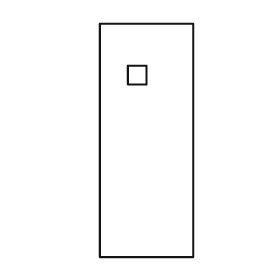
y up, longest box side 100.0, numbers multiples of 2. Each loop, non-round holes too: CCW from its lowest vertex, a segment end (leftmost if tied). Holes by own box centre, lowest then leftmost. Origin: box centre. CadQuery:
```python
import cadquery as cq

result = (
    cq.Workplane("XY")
    .moveTo(-20.0, -50.0)
    .lineTo(20.0, -50.0)
    .lineTo(20.0, 50.0)
    .lineTo(-20.0, 50.0)
    .close()
    .moveTo(-8.0, 24.0)
    .lineTo(0.0, 24.0)
    .lineTo(0.0, 32.0)
    .lineTo(-8.0, 32.0)
    .close()
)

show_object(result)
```